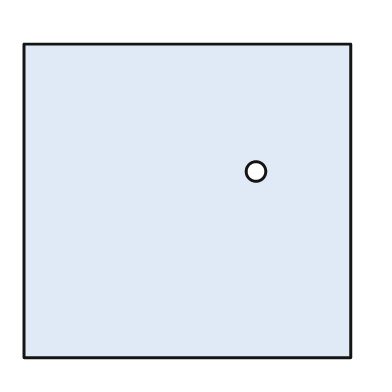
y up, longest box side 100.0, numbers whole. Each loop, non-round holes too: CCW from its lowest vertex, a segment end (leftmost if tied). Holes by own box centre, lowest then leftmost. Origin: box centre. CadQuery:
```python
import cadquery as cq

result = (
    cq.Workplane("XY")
    .moveTo(-50.0, -48.0)
    .lineTo(50.0, -48.0)
    .lineTo(50.0, 48.0)
    .lineTo(-50.0, 48.0)
    .close()
    .moveTo(21.0, 9.0)
    .circle(3.0)
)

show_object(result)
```